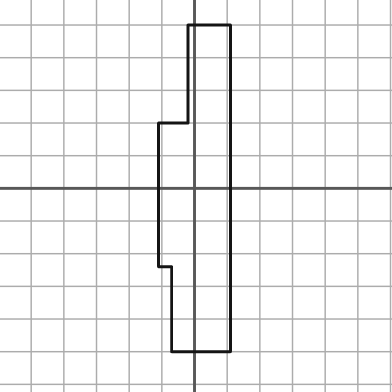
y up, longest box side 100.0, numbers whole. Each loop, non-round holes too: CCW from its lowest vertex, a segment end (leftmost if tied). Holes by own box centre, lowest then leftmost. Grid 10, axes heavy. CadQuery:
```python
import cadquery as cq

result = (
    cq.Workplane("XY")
    .moveTo(-7.0, -50.0)
    .lineTo(11.0, -50.0)
    .lineTo(11.0, 50.0)
    .lineTo(-2.0, 50.0)
    .lineTo(-2.0, 20.0)
    .lineTo(-11.0, 20.0)
    .lineTo(-11.0, -24.0)
    .lineTo(-7.0, -24.0)
    .close()
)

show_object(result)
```